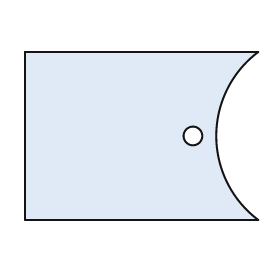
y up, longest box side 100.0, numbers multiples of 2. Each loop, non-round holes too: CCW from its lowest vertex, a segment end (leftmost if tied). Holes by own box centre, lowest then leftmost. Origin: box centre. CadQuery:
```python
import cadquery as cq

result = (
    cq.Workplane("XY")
    .moveTo(-50.0, -36.0)
    .lineTo(50.0, -36.0)
    .threePointArc((32.0, 0.0), (50.0, 36.0))
    .lineTo(-50.0, 36.0)
    .close()
    .moveTo(22.0, 0.0)
    .circle(4.0)
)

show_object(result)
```